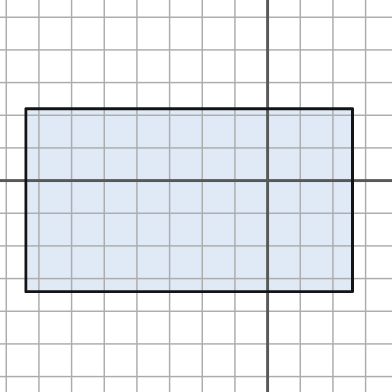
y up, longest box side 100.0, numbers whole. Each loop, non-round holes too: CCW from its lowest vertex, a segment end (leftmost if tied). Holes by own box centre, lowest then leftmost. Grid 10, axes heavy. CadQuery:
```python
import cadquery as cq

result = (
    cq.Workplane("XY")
    .moveTo(-74.0, -34.0)
    .lineTo(26.0, -34.0)
    .lineTo(26.0, 22.0)
    .lineTo(-74.0, 22.0)
    .close()
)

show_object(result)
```